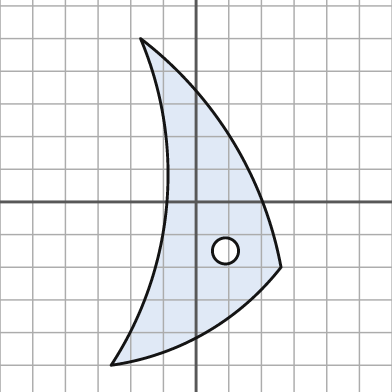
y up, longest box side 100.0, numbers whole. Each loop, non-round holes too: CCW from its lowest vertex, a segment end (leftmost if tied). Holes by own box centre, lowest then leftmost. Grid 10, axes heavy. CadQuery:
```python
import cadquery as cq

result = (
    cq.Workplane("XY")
    .moveTo(-26.0, -50.0)
    .threePointArc((3.0, -40.0), (26.0, -20.0))
    .threePointArc((11.0, 19.0), (-17.0, 50.0))
    .threePointArc((-9.0, -1.0), (-26.0, -50.0))
    .close()
    .moveTo(9.0, -15.0)
    .circle(4.0)
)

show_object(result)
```